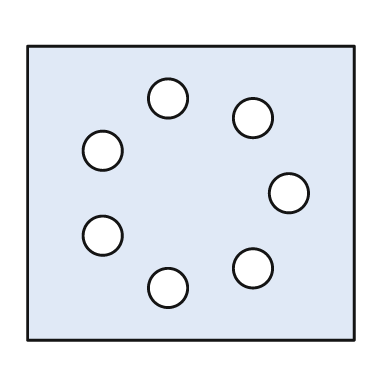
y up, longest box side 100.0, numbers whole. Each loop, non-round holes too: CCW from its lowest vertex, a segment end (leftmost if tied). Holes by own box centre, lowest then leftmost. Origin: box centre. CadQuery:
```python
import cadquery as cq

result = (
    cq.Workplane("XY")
    .moveTo(-50.0, -45.0)
    .lineTo(50.0, -45.0)
    .lineTo(50.0, 45.0)
    .lineTo(-50.0, 45.0)
    .close()
    .moveTo(-7.0, -29.0)
    .circle(6.0)
    .moveTo(19.0, -23.0)
    .circle(6.0)
    .moveTo(-27.0, -13.0)
    .circle(6.0)
    .moveTo(30.0, 0.0)
    .circle(6.0)
    .moveTo(-27.0, 13.0)
    .circle(6.0)
    .moveTo(19.0, 23.0)
    .circle(6.0)
    .moveTo(-7.0, 29.0)
    .circle(6.0)
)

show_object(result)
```